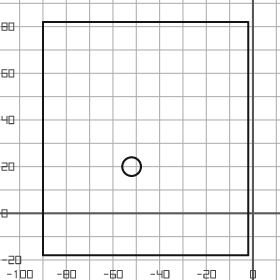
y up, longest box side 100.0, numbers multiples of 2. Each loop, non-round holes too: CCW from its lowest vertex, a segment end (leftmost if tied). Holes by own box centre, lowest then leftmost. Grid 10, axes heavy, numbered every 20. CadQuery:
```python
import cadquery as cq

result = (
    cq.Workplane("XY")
    .moveTo(-90.0, -18.0)
    .lineTo(-2.0, -18.0)
    .lineTo(-2.0, 82.0)
    .lineTo(-90.0, 82.0)
    .close()
    .moveTo(-52.0, 20.0)
    .circle(4.0)
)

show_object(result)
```